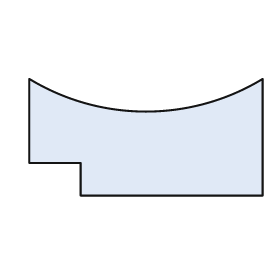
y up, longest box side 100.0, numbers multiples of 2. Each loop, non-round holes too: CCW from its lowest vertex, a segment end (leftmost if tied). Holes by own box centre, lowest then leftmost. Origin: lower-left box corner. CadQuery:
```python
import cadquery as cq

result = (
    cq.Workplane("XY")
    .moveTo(22.0, 0.0)
    .lineTo(100.0, 0.0)
    .lineTo(100.0, 50.0)
    .threePointArc((50.0, 36.0), (0.0, 50.0))
    .lineTo(0.0, 14.0)
    .lineTo(22.0, 14.0)
    .close()
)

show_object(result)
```